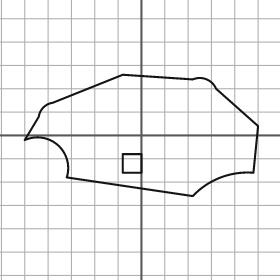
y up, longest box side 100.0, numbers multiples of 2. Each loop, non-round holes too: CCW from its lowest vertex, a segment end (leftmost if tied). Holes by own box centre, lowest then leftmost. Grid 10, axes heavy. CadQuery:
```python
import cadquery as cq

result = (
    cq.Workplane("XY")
    .moveTo(22.0, -26.0)
    .threePointArc((34.0, -18.0), (48.0, -16.0))
    .lineTo(50.0, 4.0)
    .lineTo(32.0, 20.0)
    .threePointArc((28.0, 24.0), (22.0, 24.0))
    .lineTo(-8.0, 26.0)
    .lineTo(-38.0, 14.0)
    .threePointArc((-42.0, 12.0), (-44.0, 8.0))
    .lineTo(-50.0, -2.0)
    .threePointArc((-36.0, -4.0), (-32.0, -18.0))
    .close()
    .moveTo(-8.0, -16.0)
    .lineTo(0.0, -16.0)
    .lineTo(0.0, -8.0)
    .lineTo(-8.0, -8.0)
    .close()
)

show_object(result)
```